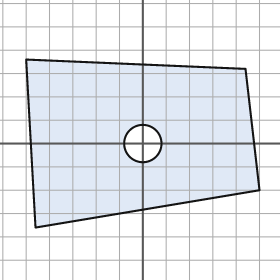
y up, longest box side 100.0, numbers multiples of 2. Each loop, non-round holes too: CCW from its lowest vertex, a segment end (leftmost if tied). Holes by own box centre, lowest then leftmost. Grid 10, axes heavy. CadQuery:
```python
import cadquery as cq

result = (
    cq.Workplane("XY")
    .moveTo(-46.0, -36.0)
    .lineTo(50.0, -20.0)
    .lineTo(44.0, 32.0)
    .lineTo(-50.0, 36.0)
    .close()
    .moveTo(0.0, 0.0)
    .circle(8.0)
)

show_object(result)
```